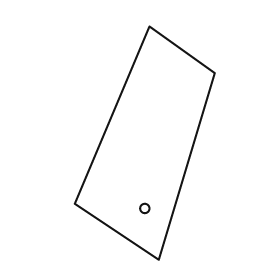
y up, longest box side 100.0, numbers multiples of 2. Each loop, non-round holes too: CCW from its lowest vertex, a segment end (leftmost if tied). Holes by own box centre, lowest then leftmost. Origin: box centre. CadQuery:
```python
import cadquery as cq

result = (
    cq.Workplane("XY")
    .moveTo(6.0, -50.0)
    .lineTo(30.0, 30.0)
    .lineTo(2.0, 50.0)
    .lineTo(-30.0, -26.0)
    .close()
    .moveTo(0.0, -28.0)
    .circle(2.0)
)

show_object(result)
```